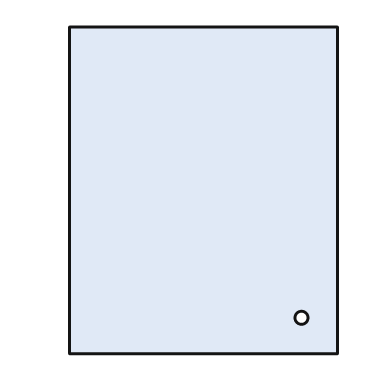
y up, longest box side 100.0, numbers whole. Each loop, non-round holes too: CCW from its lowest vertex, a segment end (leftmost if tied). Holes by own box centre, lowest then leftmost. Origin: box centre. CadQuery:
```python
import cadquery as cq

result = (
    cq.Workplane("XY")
    .moveTo(-41.0, -50.0)
    .lineTo(41.0, -50.0)
    .lineTo(41.0, 50.0)
    .lineTo(-41.0, 50.0)
    .close()
    .moveTo(30.0, -39.0)
    .circle(2.0)
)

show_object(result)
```